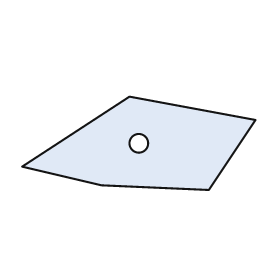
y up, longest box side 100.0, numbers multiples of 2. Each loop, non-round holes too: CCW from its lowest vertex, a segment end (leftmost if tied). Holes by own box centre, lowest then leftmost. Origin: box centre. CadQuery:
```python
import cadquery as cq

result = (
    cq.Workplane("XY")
    .moveTo(30.0, -20.0)
    .lineTo(50.0, 10.0)
    .lineTo(-4.0, 20.0)
    .lineTo(-50.0, -10.0)
    .lineTo(-16.0, -18.0)
    .close()
    .moveTo(0.0, 0.0)
    .circle(4.0)
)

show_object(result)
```